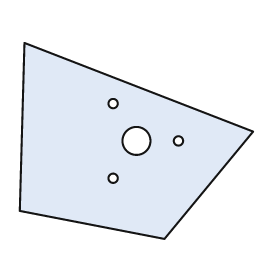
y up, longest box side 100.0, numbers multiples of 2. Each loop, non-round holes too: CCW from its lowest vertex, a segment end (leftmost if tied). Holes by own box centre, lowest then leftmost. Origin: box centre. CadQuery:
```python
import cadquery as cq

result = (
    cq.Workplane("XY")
    .moveTo(12.0, -42.0)
    .lineTo(50.0, 4.0)
    .lineTo(-48.0, 42.0)
    .lineTo(-50.0, -30.0)
    .close()
    .moveTo(-10.0, -16.0)
    .circle(2.0)
    .moveTo(0.0, 0.0)
    .circle(6.0)
    .moveTo(18.0, 0.0)
    .circle(2.0)
    .moveTo(-10.0, 16.0)
    .circle(2.0)
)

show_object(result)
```